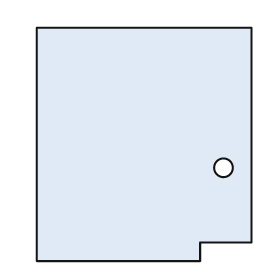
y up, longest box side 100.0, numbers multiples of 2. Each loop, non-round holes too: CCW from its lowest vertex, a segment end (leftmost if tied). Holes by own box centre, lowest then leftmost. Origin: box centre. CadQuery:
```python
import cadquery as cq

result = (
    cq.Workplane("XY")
    .moveTo(-46.0, -50.0)
    .lineTo(24.0, -50.0)
    .lineTo(24.0, -42.0)
    .lineTo(46.0, -42.0)
    .lineTo(46.0, 50.0)
    .lineTo(-46.0, 50.0)
    .close()
    .moveTo(34.0, -10.0)
    .circle(4.0)
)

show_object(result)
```